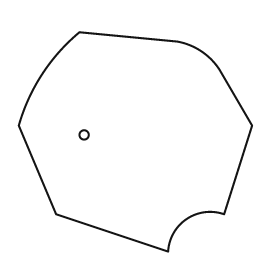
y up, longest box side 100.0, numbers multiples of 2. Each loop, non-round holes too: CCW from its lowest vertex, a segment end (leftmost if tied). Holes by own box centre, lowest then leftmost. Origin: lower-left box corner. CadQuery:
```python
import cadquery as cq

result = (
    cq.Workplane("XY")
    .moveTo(64.0, 0.0)
    .threePointArc((72.0, 14.0), (88.0, 16.0))
    .lineTo(100.0, 54.0)
    .lineTo(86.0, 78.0)
    .threePointArc((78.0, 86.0), (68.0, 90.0))
    .lineTo(26.0, 94.0)
    .threePointArc((10.0, 76.0), (0.0, 54.0))
    .lineTo(16.0, 16.0)
    .close()
    .moveTo(28.0, 50.0)
    .circle(2.0)
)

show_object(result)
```